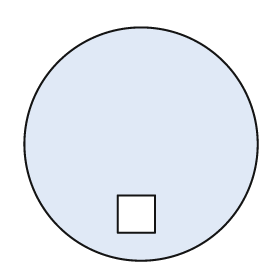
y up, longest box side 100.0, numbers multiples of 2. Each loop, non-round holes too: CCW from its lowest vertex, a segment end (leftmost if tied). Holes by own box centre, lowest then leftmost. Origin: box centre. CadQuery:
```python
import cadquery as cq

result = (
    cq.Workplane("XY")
    .moveTo(0.0, 0.0)
    .circle(50.0)
    .moveTo(-10.0, -38.0)
    .lineTo(6.0, -38.0)
    .lineTo(6.0, -22.0)
    .lineTo(-10.0, -22.0)
    .close()
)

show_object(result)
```